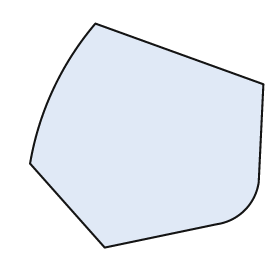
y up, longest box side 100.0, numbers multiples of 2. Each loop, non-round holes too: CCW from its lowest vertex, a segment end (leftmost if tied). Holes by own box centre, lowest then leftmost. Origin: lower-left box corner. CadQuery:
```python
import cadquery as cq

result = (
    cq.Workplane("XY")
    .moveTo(32.0, 0.0)
    .lineTo(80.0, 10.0)
    .threePointArc((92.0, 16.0), (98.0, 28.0))
    .lineTo(100.0, 70.0)
    .lineTo(28.0, 96.0)
    .threePointArc((10.0, 68.0), (0.0, 36.0))
    .close()
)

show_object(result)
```